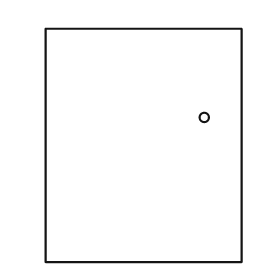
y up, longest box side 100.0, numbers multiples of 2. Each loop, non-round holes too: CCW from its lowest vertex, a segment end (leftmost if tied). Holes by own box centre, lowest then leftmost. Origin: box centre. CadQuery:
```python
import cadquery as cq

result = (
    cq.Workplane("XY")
    .moveTo(-42.0, -50.0)
    .lineTo(42.0, -50.0)
    .lineTo(42.0, 50.0)
    .lineTo(-42.0, 50.0)
    .close()
    .moveTo(26.0, 12.0)
    .circle(2.0)
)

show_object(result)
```